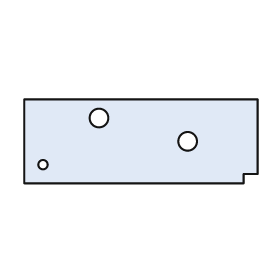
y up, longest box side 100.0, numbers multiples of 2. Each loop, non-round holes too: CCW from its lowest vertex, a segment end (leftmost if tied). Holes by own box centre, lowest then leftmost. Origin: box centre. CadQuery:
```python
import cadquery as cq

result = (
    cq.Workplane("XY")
    .moveTo(-50.0, -18.0)
    .lineTo(44.0, -18.0)
    .lineTo(44.0, -14.0)
    .lineTo(50.0, -14.0)
    .lineTo(50.0, 18.0)
    .lineTo(-50.0, 18.0)
    .close()
    .moveTo(-42.0, -10.0)
    .circle(2.0)
    .moveTo(20.0, 0.0)
    .circle(4.0)
    .moveTo(-18.0, 10.0)
    .circle(4.0)
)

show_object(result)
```